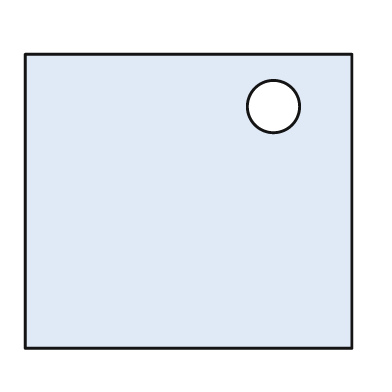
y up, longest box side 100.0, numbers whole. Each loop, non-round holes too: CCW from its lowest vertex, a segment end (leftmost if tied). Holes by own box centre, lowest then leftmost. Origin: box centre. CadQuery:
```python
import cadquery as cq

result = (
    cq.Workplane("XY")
    .moveTo(-50.0, -45.0)
    .lineTo(50.0, -45.0)
    .lineTo(50.0, 45.0)
    .lineTo(-50.0, 45.0)
    .close()
    .moveTo(26.0, 29.0)
    .circle(8.0)
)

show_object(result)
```